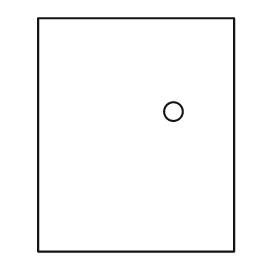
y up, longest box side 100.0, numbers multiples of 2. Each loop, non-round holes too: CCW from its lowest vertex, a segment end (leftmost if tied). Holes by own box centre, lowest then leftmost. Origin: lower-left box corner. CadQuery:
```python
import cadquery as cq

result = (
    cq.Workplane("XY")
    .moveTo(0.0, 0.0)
    .lineTo(84.0, 0.0)
    .lineTo(84.0, 100.0)
    .lineTo(0.0, 100.0)
    .close()
    .moveTo(58.0, 60.0)
    .circle(4.0)
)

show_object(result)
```